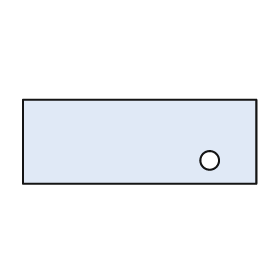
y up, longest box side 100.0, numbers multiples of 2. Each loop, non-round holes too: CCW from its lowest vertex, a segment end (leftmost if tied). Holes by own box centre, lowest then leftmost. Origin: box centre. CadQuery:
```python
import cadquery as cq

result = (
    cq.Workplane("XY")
    .moveTo(-50.0, -18.0)
    .lineTo(50.0, -18.0)
    .lineTo(50.0, 18.0)
    .lineTo(-50.0, 18.0)
    .close()
    .moveTo(30.0, -8.0)
    .circle(4.0)
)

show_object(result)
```